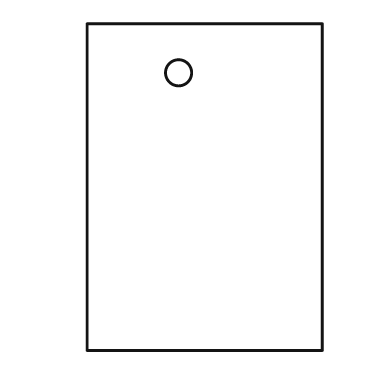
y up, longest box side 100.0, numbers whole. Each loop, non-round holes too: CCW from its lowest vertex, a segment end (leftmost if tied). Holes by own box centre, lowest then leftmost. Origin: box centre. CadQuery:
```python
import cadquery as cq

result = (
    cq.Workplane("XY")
    .moveTo(-36.0, -50.0)
    .lineTo(36.0, -50.0)
    .lineTo(36.0, 50.0)
    .lineTo(-36.0, 50.0)
    .close()
    .moveTo(-8.0, 35.0)
    .circle(4.0)
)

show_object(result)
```